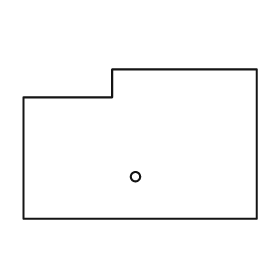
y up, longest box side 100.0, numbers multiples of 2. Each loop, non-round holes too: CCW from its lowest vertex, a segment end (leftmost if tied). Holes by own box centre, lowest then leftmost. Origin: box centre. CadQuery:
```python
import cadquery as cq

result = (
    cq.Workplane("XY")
    .moveTo(-50.0, -32.0)
    .lineTo(50.0, -32.0)
    .lineTo(50.0, 32.0)
    .lineTo(-12.0, 32.0)
    .lineTo(-12.0, 20.0)
    .lineTo(-50.0, 20.0)
    .close()
    .moveTo(-2.0, -14.0)
    .circle(2.0)
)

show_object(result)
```